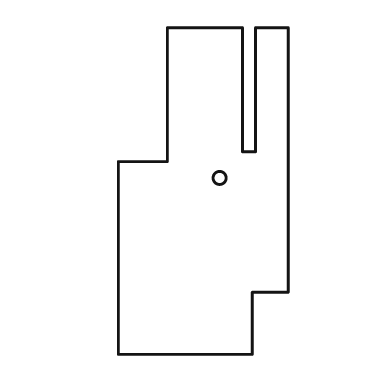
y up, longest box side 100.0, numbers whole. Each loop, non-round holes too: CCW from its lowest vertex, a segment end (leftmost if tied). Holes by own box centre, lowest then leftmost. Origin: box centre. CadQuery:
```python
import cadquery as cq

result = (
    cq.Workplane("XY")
    .moveTo(-26.0, -50.0)
    .lineTo(15.0, -50.0)
    .lineTo(15.0, -31.0)
    .lineTo(26.0, -31.0)
    .lineTo(26.0, 50.0)
    .lineTo(16.0, 50.0)
    .lineTo(16.0, 12.0)
    .lineTo(12.0, 12.0)
    .lineTo(12.0, 50.0)
    .lineTo(-11.0, 50.0)
    .lineTo(-11.0, 9.0)
    .lineTo(-26.0, 9.0)
    .close()
    .moveTo(5.0, 4.0)
    .circle(2.0)
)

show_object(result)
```